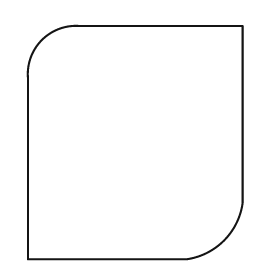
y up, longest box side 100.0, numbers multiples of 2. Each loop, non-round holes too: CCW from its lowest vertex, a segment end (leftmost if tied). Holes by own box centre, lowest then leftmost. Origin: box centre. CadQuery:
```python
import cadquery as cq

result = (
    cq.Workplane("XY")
    .moveTo(-46.0, -50.0)
    .lineTo(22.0, -50.0)
    .threePointArc((38.0, -42.0), (46.0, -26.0))
    .lineTo(46.0, 50.0)
    .lineTo(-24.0, 50.0)
    .threePointArc((-40.0, 44.0), (-46.0, 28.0))
    .close()
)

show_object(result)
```